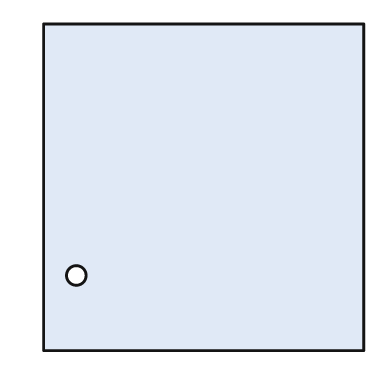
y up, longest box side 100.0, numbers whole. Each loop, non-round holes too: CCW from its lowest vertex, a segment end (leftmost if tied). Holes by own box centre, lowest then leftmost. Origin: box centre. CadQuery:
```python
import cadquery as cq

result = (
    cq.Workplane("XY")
    .moveTo(-49.0, -50.0)
    .lineTo(49.0, -50.0)
    .lineTo(49.0, 50.0)
    .lineTo(-49.0, 50.0)
    .close()
    .moveTo(-39.0, -27.0)
    .circle(3.0)
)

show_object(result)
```